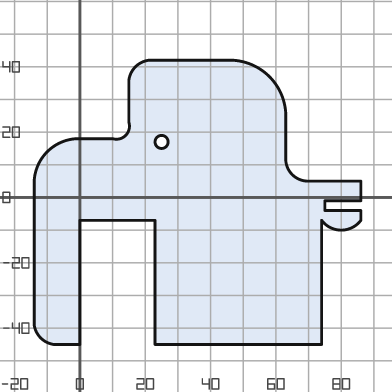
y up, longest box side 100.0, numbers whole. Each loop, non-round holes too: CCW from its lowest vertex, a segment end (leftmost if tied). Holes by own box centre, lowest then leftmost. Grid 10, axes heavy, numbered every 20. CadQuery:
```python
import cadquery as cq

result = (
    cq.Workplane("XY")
    .moveTo(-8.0, -45.0)
    .lineTo(0.0, -45.0)
    .lineTo(0.0, -7.0)
    .lineTo(23.0, -7.0)
    .lineTo(23.0, -45.0)
    .lineTo(74.0, -45.0)
    .lineTo(74.0, -7.0)
    .threePointArc((80.0, -10.0), (86.0, -7.0))
    .lineTo(86.0, -4.0)
    .lineTo(75.0, -4.0)
    .lineTo(75.0, -1.0)
    .lineTo(86.0, -1.0)
    .lineTo(86.0, 5.0)
    .lineTo(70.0, 5.0)
    .threePointArc((65.0, 7.0), (63.0, 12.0))
    .lineTo(63.0, 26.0)
    .threePointArc((58.0, 37.0), (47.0, 42.0))
    .lineTo(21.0, 42.0)
    .threePointArc((17.0, 40.0), (15.0, 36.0))
    .lineTo(15.0, 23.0)
    .threePointArc((14.0, 19.0), (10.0, 18.0))
    .lineTo(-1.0, 18.0)
    .threePointArc((-10.0, 14.0), (-14.0, 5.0))
    .lineTo(-14.0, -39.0)
    .threePointArc((-12.0, -43.0), (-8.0, -45.0))
    .close()
    .moveTo(25.0, 17.0)
    .circle(2.0)
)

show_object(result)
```